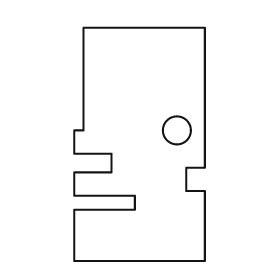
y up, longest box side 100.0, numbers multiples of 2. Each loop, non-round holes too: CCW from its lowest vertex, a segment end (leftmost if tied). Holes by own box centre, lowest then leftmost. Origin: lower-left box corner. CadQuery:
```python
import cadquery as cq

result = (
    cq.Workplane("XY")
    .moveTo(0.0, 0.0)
    .lineTo(56.0, 0.0)
    .lineTo(56.0, 30.0)
    .lineTo(48.0, 30.0)
    .lineTo(48.0, 40.0)
    .lineTo(56.0, 40.0)
    .lineTo(56.0, 100.0)
    .lineTo(4.0, 100.0)
    .lineTo(4.0, 56.0)
    .lineTo(0.0, 56.0)
    .lineTo(0.0, 46.0)
    .lineTo(16.0, 46.0)
    .lineTo(16.0, 38.0)
    .lineTo(0.0, 38.0)
    .lineTo(0.0, 28.0)
    .lineTo(26.0, 28.0)
    .lineTo(26.0, 22.0)
    .lineTo(0.0, 22.0)
    .close()
    .moveTo(44.0, 56.0)
    .circle(6.0)
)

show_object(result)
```